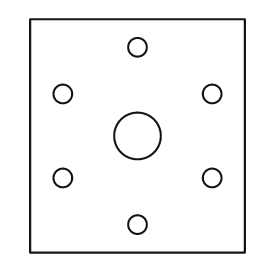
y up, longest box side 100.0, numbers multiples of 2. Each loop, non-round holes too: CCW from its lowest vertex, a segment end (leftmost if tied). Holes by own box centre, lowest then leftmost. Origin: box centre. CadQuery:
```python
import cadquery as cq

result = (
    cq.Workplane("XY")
    .moveTo(-46.0, -50.0)
    .lineTo(46.0, -50.0)
    .lineTo(46.0, 50.0)
    .lineTo(-46.0, 50.0)
    .close()
    .moveTo(0.0, -38.0)
    .circle(4.0)
    .moveTo(-32.0, -18.0)
    .circle(4.0)
    .moveTo(32.0, -18.0)
    .circle(4.0)
    .moveTo(0.0, 0.0)
    .circle(10.0)
    .moveTo(-32.0, 18.0)
    .circle(4.0)
    .moveTo(32.0, 18.0)
    .circle(4.0)
    .moveTo(0.0, 38.0)
    .circle(4.0)
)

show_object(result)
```